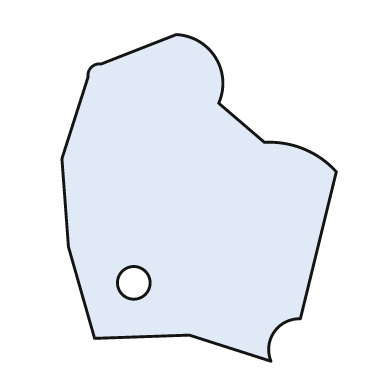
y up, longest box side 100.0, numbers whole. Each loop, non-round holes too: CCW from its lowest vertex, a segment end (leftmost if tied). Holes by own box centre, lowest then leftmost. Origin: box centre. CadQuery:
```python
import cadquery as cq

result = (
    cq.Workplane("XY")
    .moveTo(22.0, -50.0)
    .threePointArc((23.0, -41.0), (31.0, -37.0))
    .lineTo(42.0, 8.0)
    .threePointArc((32.0, 15.0), (20.0, 17.0))
    .lineTo(6.0, 29.0)
    .threePointArc((5.0, 43.0), (-7.0, 50.0))
    .lineTo(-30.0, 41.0)
    .threePointArc((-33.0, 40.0), (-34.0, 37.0))
    .lineTo(-42.0, 12.0)
    .lineTo(-40.0, -15.0)
    .lineTo(-32.0, -43.0)
    .lineTo(-3.0, -42.0)
    .close()
    .moveTo(-20.0, -26.0)
    .circle(5.0)
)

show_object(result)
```